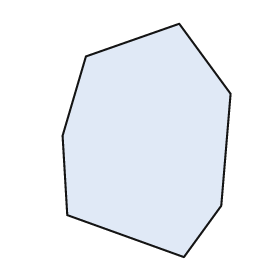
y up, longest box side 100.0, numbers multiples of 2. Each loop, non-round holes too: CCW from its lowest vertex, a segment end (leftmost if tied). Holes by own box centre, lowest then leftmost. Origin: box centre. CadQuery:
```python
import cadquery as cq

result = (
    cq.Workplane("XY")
    .moveTo(16.0, -50.0)
    .lineTo(32.0, -28.0)
    .lineTo(36.0, 20.0)
    .lineTo(14.0, 50.0)
    .lineTo(-26.0, 36.0)
    .lineTo(-36.0, 2.0)
    .lineTo(-34.0, -32.0)
    .close()
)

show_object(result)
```